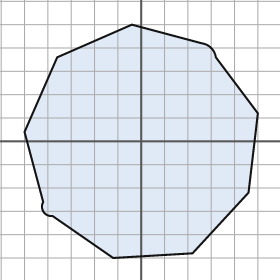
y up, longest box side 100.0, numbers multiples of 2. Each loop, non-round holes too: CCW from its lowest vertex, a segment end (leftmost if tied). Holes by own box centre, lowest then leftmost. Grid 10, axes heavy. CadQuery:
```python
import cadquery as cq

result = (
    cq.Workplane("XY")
    .moveTo(-12.0, -50.0)
    .lineTo(22.0, -48.0)
    .lineTo(46.0, -22.0)
    .lineTo(50.0, 12.0)
    .lineTo(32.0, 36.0)
    .threePointArc((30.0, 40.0), (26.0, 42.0))
    .lineTo(-4.0, 50.0)
    .lineTo(-36.0, 36.0)
    .lineTo(-50.0, 4.0)
    .lineTo(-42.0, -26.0)
    .threePointArc((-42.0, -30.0), (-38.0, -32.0))
    .close()
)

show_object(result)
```